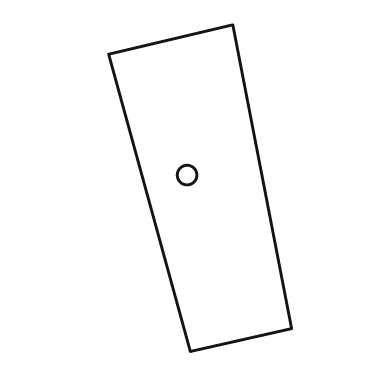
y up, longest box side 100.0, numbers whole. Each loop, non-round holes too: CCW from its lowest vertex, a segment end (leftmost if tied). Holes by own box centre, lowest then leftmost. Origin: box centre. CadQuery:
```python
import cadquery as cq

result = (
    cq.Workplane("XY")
    .moveTo(-3.0, -50.0)
    .lineTo(28.0, -43.0)
    .lineTo(10.0, 50.0)
    .lineTo(-28.0, 41.0)
    .close()
    .moveTo(-4.0, 4.0)
    .circle(3.0)
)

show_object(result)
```